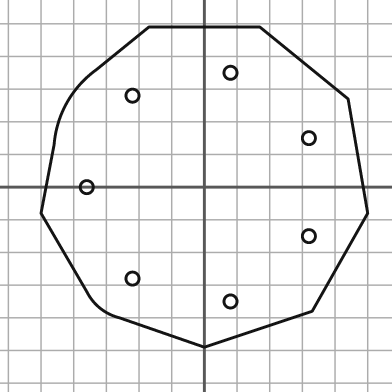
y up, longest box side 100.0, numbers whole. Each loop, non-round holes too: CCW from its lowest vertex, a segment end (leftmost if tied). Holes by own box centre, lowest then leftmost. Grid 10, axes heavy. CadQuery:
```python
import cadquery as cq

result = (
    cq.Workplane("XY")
    .moveTo(0.0, -49.0)
    .lineTo(33.0, -38.0)
    .lineTo(50.0, -8.0)
    .lineTo(44.0, 27.0)
    .lineTo(17.0, 49.0)
    .lineTo(-17.0, 49.0)
    .lineTo(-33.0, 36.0)
    .threePointArc((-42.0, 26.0), (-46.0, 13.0))
    .lineTo(-50.0, -8.0)
    .lineTo(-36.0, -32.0)
    .threePointArc((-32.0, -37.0), (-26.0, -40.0))
    .close()
    .moveTo(8.0, -35.0)
    .circle(2.0)
    .moveTo(-22.0, -28.0)
    .circle(2.0)
    .moveTo(32.0, -15.0)
    .circle(2.0)
    .moveTo(-36.0, 0.0)
    .circle(2.0)
    .moveTo(32.0, 15.0)
    .circle(2.0)
    .moveTo(-22.0, 28.0)
    .circle(2.0)
    .moveTo(8.0, 35.0)
    .circle(2.0)
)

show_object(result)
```